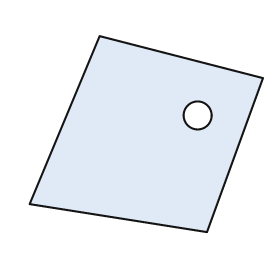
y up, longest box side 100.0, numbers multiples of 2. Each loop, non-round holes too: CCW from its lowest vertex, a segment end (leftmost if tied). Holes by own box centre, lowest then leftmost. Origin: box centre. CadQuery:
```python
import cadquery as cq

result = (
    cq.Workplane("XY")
    .moveTo(26.0, -42.0)
    .lineTo(50.0, 24.0)
    .lineTo(-20.0, 42.0)
    .lineTo(-50.0, -30.0)
    .close()
    .moveTo(22.0, 8.0)
    .circle(6.0)
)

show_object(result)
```